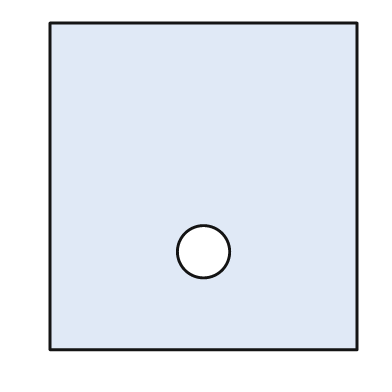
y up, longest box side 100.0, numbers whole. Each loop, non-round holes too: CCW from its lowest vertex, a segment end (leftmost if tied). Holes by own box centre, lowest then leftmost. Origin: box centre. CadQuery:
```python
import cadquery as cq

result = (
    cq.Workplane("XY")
    .moveTo(-47.0, -50.0)
    .lineTo(47.0, -50.0)
    .lineTo(47.0, 50.0)
    .lineTo(-47.0, 50.0)
    .close()
    .moveTo(0.0, -20.0)
    .circle(8.0)
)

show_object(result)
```